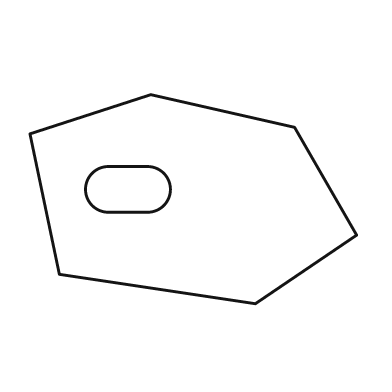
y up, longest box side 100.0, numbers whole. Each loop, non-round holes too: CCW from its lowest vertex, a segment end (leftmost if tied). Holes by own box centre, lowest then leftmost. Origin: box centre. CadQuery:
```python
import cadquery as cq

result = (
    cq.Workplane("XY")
    .moveTo(19.0, -32.0)
    .lineTo(50.0, -11.0)
    .lineTo(31.0, 22.0)
    .lineTo(-13.0, 32.0)
    .lineTo(-50.0, 20.0)
    .lineTo(-41.0, -23.0)
    .close()
    .moveTo(-26.0, -4.0)
    .lineTo(-14.0, -4.0)
    .threePointArc((-7.0, 3.0), (-14.0, 10.0))
    .lineTo(-26.0, 10.0)
    .threePointArc((-33.0, 3.0), (-26.0, -4.0))
    .close()
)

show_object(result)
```